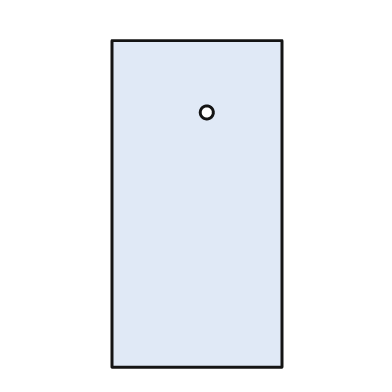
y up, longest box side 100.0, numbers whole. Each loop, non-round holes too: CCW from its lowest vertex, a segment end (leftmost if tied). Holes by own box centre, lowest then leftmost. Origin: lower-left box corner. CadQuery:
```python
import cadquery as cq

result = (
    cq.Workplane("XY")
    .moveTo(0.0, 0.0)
    .lineTo(52.0, 0.0)
    .lineTo(52.0, 100.0)
    .lineTo(0.0, 100.0)
    .close()
    .moveTo(29.0, 78.0)
    .circle(2.0)
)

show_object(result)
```